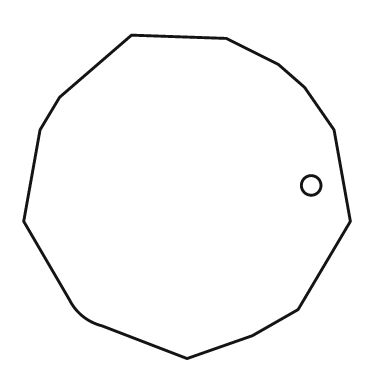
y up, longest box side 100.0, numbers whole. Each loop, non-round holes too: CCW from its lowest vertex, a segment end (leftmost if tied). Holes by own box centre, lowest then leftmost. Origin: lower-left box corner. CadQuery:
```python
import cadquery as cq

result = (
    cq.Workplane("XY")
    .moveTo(50.0, 0.0)
    .lineTo(70.0, 7.0)
    .lineTo(84.0, 15.0)
    .lineTo(100.0, 42.0)
    .lineTo(95.0, 70.0)
    .lineTo(86.0, 83.0)
    .lineTo(78.0, 90.0)
    .lineTo(62.0, 98.0)
    .lineTo(33.0, 99.0)
    .lineTo(11.0, 80.0)
    .lineTo(5.0, 70.0)
    .lineTo(0.0, 42.0)
    .lineTo(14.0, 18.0)
    .threePointArc((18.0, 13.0), (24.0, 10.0))
    .close()
    .moveTo(88.0, 53.0)
    .circle(3.0)
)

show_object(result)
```